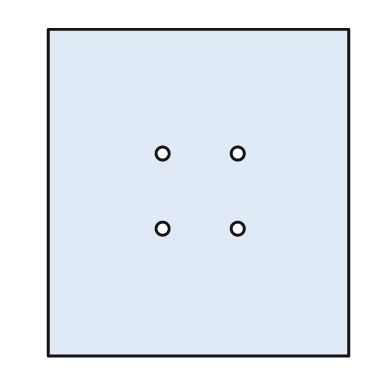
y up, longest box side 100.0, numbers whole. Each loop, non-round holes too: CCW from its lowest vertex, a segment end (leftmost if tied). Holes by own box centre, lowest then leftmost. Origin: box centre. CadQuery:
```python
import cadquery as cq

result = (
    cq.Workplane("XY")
    .moveTo(-46.0, -50.0)
    .lineTo(46.0, -50.0)
    .lineTo(46.0, 50.0)
    .lineTo(-46.0, 50.0)
    .close()
    .moveTo(-11.0, -11.0)
    .circle(2.0)
    .moveTo(12.0, -11.0)
    .circle(2.0)
    .moveTo(-11.0, 12.0)
    .circle(2.0)
    .moveTo(12.0, 12.0)
    .circle(2.0)
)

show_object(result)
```